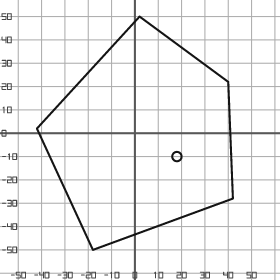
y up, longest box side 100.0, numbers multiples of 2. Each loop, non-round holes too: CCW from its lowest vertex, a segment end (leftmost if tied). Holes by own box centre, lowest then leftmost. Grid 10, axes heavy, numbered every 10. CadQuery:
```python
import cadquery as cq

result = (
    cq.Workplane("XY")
    .moveTo(-18.0, -50.0)
    .lineTo(42.0, -28.0)
    .lineTo(40.0, 22.0)
    .lineTo(2.0, 50.0)
    .lineTo(-42.0, 2.0)
    .close()
    .moveTo(18.0, -10.0)
    .circle(2.0)
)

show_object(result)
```